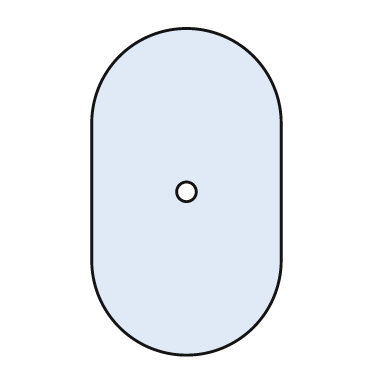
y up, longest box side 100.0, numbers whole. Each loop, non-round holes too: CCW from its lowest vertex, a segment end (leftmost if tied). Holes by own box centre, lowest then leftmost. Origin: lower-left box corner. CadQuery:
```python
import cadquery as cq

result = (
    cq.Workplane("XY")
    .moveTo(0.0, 29.0)
    .threePointArc((29.0, 0.0), (58.0, 29.0))
    .lineTo(58.0, 71.0)
    .threePointArc((29.0, 100.0), (0.0, 71.0))
    .close()
    .moveTo(29.0, 50.0)
    .circle(3.0)
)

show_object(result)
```